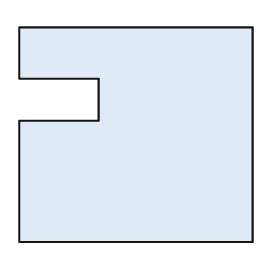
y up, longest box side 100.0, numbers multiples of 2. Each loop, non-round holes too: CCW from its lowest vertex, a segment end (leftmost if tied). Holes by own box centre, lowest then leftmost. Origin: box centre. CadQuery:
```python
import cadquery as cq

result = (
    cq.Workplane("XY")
    .moveTo(-50.0, -46.0)
    .lineTo(50.0, -46.0)
    .lineTo(50.0, 46.0)
    .lineTo(-50.0, 46.0)
    .lineTo(-50.0, 24.0)
    .lineTo(-16.0, 24.0)
    .lineTo(-16.0, 6.0)
    .lineTo(-50.0, 6.0)
    .close()
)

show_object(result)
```